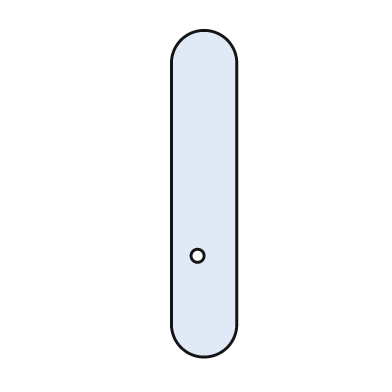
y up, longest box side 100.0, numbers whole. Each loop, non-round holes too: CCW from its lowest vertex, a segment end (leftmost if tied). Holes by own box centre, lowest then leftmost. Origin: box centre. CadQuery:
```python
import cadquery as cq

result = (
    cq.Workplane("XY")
    .moveTo(-10.0, -40.0)
    .threePointArc((0.0, -50.0), (10.0, -40.0))
    .lineTo(10.0, 40.0)
    .threePointArc((0.0, 50.0), (-10.0, 40.0))
    .close()
    .moveTo(-2.0, -19.0)
    .circle(2.0)
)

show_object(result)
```